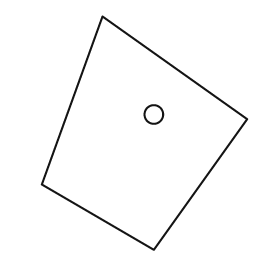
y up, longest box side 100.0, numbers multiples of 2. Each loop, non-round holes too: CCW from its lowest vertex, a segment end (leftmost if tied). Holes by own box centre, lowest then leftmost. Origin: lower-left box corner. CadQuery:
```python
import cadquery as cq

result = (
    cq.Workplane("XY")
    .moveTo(48.0, 0.0)
    .lineTo(88.0, 56.0)
    .lineTo(26.0, 100.0)
    .lineTo(0.0, 28.0)
    .close()
    .moveTo(48.0, 58.0)
    .circle(4.0)
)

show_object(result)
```